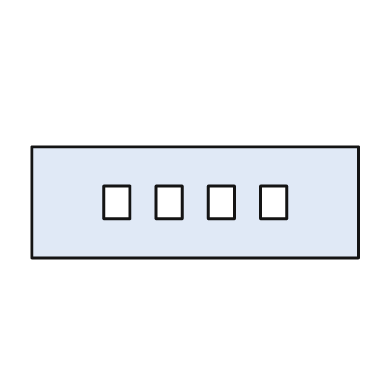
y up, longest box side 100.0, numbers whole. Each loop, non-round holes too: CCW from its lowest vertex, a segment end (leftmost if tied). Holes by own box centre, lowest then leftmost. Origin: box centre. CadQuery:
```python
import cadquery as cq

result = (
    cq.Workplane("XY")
    .moveTo(-50.0, -17.0)
    .lineTo(50.0, -17.0)
    .lineTo(50.0, 17.0)
    .lineTo(-50.0, 17.0)
    .close()
    .moveTo(-28.0, -5.0)
    .lineTo(-20.0, -5.0)
    .lineTo(-20.0, 5.0)
    .lineTo(-28.0, 5.0)
    .close()
    .moveTo(-12.0, -5.0)
    .lineTo(-4.0, -5.0)
    .lineTo(-4.0, 5.0)
    .lineTo(-12.0, 5.0)
    .close()
    .moveTo(4.0, -5.0)
    .lineTo(12.0, -5.0)
    .lineTo(12.0, 5.0)
    .lineTo(4.0, 5.0)
    .close()
    .moveTo(20.0, -5.0)
    .lineTo(28.0, -5.0)
    .lineTo(28.0, 5.0)
    .lineTo(20.0, 5.0)
    .close()
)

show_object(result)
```